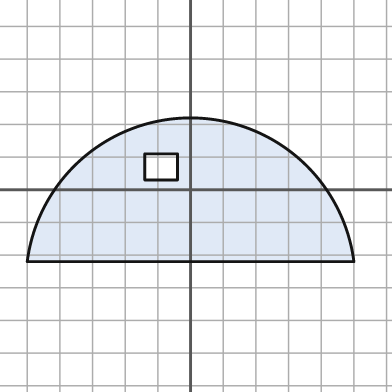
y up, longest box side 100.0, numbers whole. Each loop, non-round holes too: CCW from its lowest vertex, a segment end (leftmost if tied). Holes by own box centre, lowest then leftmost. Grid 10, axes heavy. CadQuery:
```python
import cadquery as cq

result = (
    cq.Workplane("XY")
    .moveTo(-50.0, -22.0)
    .lineTo(50.0, -22.0)
    .threePointArc((0.0, 22.0), (-50.0, -22.0))
    .close()
    .moveTo(-14.0, 3.0)
    .lineTo(-4.0, 3.0)
    .lineTo(-4.0, 11.0)
    .lineTo(-14.0, 11.0)
    .close()
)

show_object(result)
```